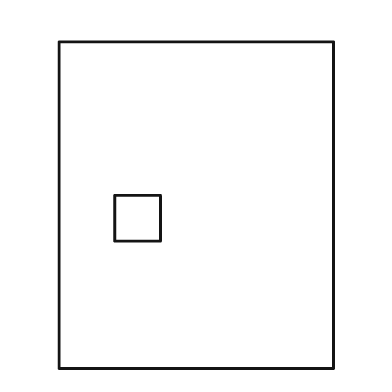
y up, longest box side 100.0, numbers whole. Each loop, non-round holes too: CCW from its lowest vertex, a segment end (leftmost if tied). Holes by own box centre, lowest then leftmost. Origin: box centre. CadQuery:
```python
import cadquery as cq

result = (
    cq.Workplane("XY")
    .moveTo(-42.0, -50.0)
    .lineTo(42.0, -50.0)
    .lineTo(42.0, 50.0)
    .lineTo(-42.0, 50.0)
    .close()
    .moveTo(-25.0, -11.0)
    .lineTo(-11.0, -11.0)
    .lineTo(-11.0, 3.0)
    .lineTo(-25.0, 3.0)
    .close()
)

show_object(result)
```